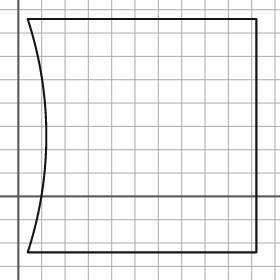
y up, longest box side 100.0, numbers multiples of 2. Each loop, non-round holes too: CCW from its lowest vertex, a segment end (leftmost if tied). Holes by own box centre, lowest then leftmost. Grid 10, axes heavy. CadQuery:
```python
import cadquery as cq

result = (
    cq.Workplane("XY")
    .moveTo(4.0, -24.0)
    .lineTo(102.0, -24.0)
    .lineTo(102.0, 76.0)
    .lineTo(4.0, 76.0)
    .threePointArc((12.0, 26.0), (4.0, -24.0))
    .close()
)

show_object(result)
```